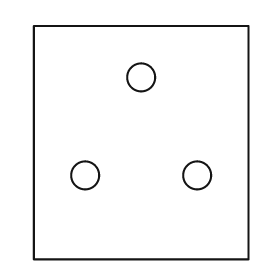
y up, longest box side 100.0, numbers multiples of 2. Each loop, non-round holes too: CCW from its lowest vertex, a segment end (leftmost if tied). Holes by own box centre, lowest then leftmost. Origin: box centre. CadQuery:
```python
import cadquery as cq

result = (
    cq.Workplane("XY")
    .moveTo(-46.0, -50.0)
    .lineTo(46.0, -50.0)
    .lineTo(46.0, 50.0)
    .lineTo(-46.0, 50.0)
    .close()
    .moveTo(-24.0, -14.0)
    .circle(6.0)
    .moveTo(24.0, -14.0)
    .circle(6.0)
    .moveTo(0.0, 28.0)
    .circle(6.0)
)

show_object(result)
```